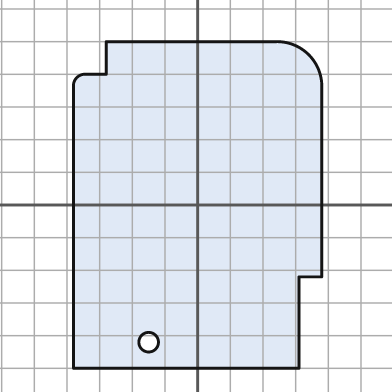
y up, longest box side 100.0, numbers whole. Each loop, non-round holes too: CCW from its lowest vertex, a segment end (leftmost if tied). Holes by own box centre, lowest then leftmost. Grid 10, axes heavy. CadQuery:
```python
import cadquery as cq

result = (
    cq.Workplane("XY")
    .moveTo(-38.0, -50.0)
    .lineTo(31.0, -50.0)
    .lineTo(31.0, -22.0)
    .lineTo(38.0, -22.0)
    .lineTo(38.0, 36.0)
    .threePointArc((34.0, 46.0), (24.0, 50.0))
    .lineTo(-28.0, 50.0)
    .lineTo(-28.0, 40.0)
    .lineTo(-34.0, 40.0)
    .threePointArc((-37.0, 39.0), (-38.0, 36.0))
    .close()
    .moveTo(-15.0, -42.0)
    .circle(3.0)
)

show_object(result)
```